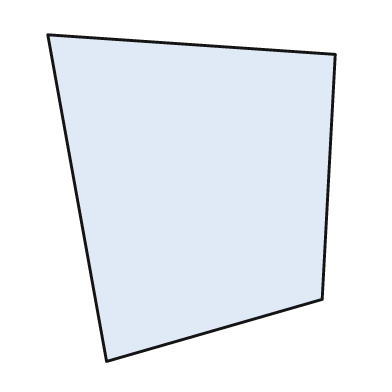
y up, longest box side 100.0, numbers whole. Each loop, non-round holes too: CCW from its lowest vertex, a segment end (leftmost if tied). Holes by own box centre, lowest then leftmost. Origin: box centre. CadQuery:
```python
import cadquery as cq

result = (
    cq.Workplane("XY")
    .moveTo(-26.0, -50.0)
    .lineTo(40.0, -31.0)
    .lineTo(44.0, 44.0)
    .lineTo(-44.0, 50.0)
    .close()
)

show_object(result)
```